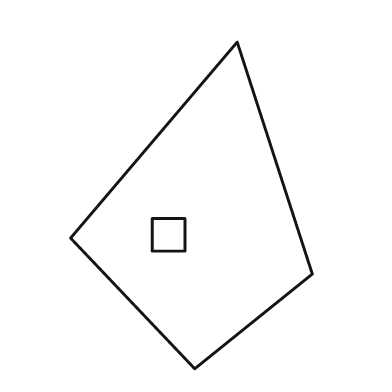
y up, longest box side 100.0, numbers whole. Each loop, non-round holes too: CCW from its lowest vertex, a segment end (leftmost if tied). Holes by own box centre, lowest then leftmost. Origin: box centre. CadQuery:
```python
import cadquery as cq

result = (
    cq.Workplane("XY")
    .moveTo(1.0, -50.0)
    .lineTo(37.0, -21.0)
    .lineTo(14.0, 50.0)
    .lineTo(-37.0, -10.0)
    .close()
    .moveTo(-12.0, -14.0)
    .lineTo(-2.0, -14.0)
    .lineTo(-2.0, -4.0)
    .lineTo(-12.0, -4.0)
    .close()
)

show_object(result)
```